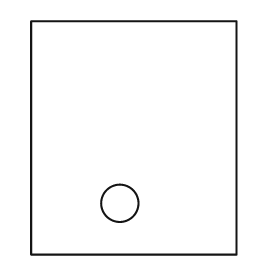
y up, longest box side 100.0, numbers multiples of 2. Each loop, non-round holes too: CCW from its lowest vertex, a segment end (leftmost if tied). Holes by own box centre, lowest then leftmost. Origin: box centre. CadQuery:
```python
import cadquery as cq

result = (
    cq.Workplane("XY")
    .moveTo(-44.0, -50.0)
    .lineTo(44.0, -50.0)
    .lineTo(44.0, 50.0)
    .lineTo(-44.0, 50.0)
    .close()
    .moveTo(-6.0, -28.0)
    .circle(8.0)
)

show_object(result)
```